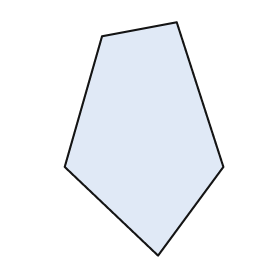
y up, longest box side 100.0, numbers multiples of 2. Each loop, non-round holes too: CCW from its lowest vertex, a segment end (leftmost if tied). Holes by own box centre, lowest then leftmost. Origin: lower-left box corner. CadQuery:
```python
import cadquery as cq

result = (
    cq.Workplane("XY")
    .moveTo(40.0, 0.0)
    .lineTo(68.0, 38.0)
    .lineTo(48.0, 100.0)
    .lineTo(16.0, 94.0)
    .lineTo(0.0, 38.0)
    .close()
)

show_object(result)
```